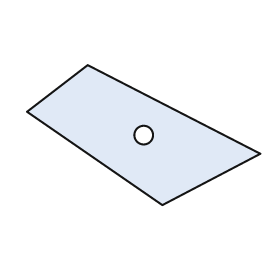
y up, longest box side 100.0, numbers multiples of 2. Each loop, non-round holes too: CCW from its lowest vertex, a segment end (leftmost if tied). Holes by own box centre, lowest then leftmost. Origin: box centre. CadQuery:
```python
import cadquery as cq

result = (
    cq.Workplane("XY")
    .moveTo(8.0, -30.0)
    .lineTo(50.0, -8.0)
    .lineTo(-24.0, 30.0)
    .lineTo(-50.0, 10.0)
    .close()
    .moveTo(0.0, 0.0)
    .circle(4.0)
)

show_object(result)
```